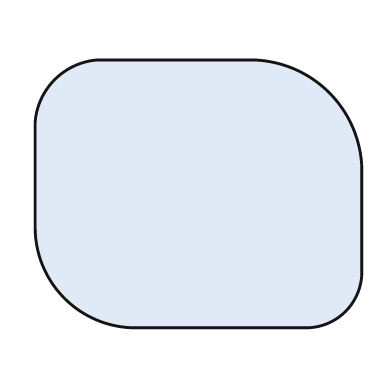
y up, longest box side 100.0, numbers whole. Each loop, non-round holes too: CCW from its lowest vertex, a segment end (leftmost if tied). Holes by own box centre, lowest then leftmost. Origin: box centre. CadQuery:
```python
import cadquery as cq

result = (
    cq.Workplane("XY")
    .moveTo(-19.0, -41.0)
    .lineTo(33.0, -41.0)
    .threePointArc((45.0, -36.0), (50.0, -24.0))
    .lineTo(50.0, 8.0)
    .threePointArc((40.0, 31.0), (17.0, 41.0))
    .lineTo(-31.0, 41.0)
    .threePointArc((-44.0, 35.0), (-50.0, 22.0))
    .lineTo(-50.0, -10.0)
    .threePointArc((-41.0, -32.0), (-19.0, -41.0))
    .close()
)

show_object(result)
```